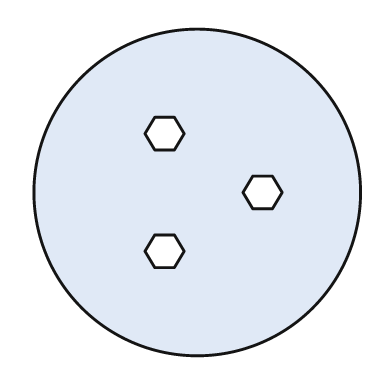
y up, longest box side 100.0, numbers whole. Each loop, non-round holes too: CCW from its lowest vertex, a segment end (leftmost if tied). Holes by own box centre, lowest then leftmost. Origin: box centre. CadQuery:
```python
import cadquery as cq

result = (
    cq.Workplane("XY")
    .moveTo(0.0, 0.0)
    .circle(50.0)
    .moveTo(-13.0, -23.0)
    .lineTo(-7.0, -23.0)
    .lineTo(-4.0, -18.0)
    .lineTo(-7.0, -13.0)
    .lineTo(-13.0, -13.0)
    .lineTo(-16.0, -18.0)
    .close()
    .moveTo(17.0, -5.0)
    .lineTo(23.0, -5.0)
    .lineTo(26.0, 0.0)
    .lineTo(23.0, 5.0)
    .lineTo(17.0, 5.0)
    .lineTo(14.0, 0.0)
    .close()
    .moveTo(-13.0, 13.0)
    .lineTo(-7.0, 13.0)
    .lineTo(-4.0, 18.0)
    .lineTo(-7.0, 23.0)
    .lineTo(-13.0, 23.0)
    .lineTo(-16.0, 18.0)
    .close()
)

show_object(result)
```